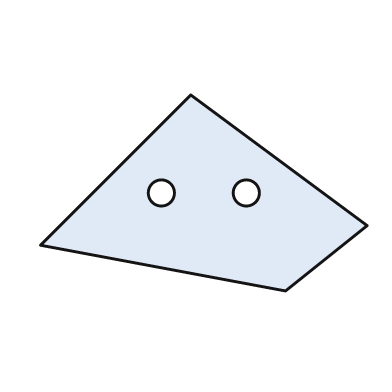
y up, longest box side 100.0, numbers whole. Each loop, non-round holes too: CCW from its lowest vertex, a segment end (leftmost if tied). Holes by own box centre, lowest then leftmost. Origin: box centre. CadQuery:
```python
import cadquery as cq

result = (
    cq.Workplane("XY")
    .moveTo(25.0, -30.0)
    .lineTo(50.0, -10.0)
    .lineTo(-4.0, 30.0)
    .lineTo(-50.0, -16.0)
    .close()
    .moveTo(-13.0, 0.0)
    .circle(4.0)
    .moveTo(13.0, 0.0)
    .circle(4.0)
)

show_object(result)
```